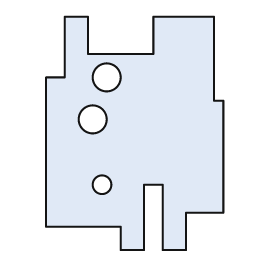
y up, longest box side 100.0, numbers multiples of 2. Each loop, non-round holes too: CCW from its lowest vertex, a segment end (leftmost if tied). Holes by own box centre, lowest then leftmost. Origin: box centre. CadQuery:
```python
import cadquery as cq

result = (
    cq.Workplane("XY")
    .moveTo(-6.0, -50.0)
    .lineTo(4.0, -50.0)
    .lineTo(4.0, -22.0)
    .lineTo(12.0, -22.0)
    .lineTo(12.0, -50.0)
    .lineTo(22.0, -50.0)
    .lineTo(22.0, -34.0)
    .lineTo(38.0, -34.0)
    .lineTo(38.0, 14.0)
    .lineTo(34.0, 14.0)
    .lineTo(34.0, 50.0)
    .lineTo(8.0, 50.0)
    .lineTo(8.0, 34.0)
    .lineTo(-20.0, 34.0)
    .lineTo(-20.0, 50.0)
    .lineTo(-30.0, 50.0)
    .lineTo(-30.0, 24.0)
    .lineTo(-38.0, 24.0)
    .lineTo(-38.0, -40.0)
    .lineTo(-6.0, -40.0)
    .close()
    .moveTo(-14.0, -22.0)
    .circle(4.0)
    .moveTo(-18.0, 6.0)
    .circle(6.0)
    .moveTo(-12.0, 24.0)
    .circle(6.0)
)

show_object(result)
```